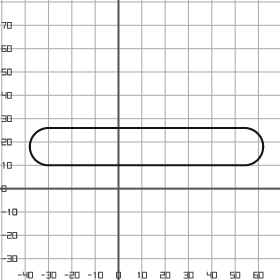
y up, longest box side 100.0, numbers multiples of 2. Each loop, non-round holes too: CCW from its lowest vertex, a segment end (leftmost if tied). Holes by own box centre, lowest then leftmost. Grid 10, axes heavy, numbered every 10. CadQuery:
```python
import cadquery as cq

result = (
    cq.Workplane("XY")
    .moveTo(-30.0, 10.0)
    .lineTo(54.0, 10.0)
    .threePointArc((62.0, 18.0), (54.0, 26.0))
    .lineTo(-30.0, 26.0)
    .threePointArc((-38.0, 18.0), (-30.0, 10.0))
    .close()
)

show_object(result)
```